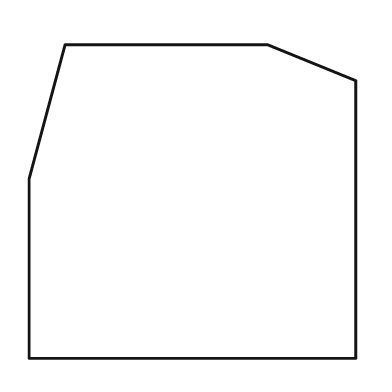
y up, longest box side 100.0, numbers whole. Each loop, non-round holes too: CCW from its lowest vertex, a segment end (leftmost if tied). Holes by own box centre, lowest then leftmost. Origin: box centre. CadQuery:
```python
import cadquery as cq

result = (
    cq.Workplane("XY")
    .moveTo(-50.0, -48.0)
    .lineTo(50.0, -48.0)
    .lineTo(50.0, 37.0)
    .lineTo(23.0, 48.0)
    .lineTo(-39.0, 48.0)
    .lineTo(-50.0, 7.0)
    .close()
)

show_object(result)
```